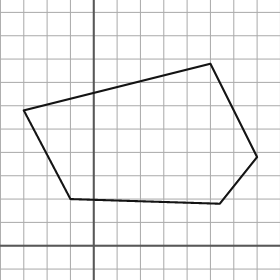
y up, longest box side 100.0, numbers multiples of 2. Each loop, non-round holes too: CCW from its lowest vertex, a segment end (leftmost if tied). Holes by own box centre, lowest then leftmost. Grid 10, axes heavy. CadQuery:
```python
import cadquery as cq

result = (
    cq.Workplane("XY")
    .moveTo(54.0, 18.0)
    .lineTo(70.0, 38.0)
    .lineTo(50.0, 78.0)
    .lineTo(-30.0, 58.0)
    .lineTo(-10.0, 20.0)
    .close()
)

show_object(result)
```